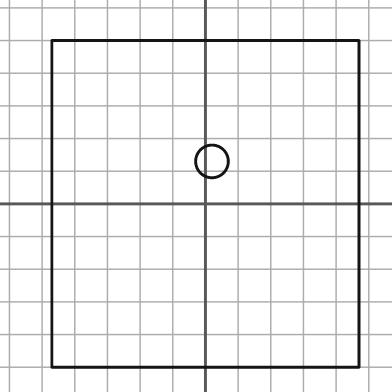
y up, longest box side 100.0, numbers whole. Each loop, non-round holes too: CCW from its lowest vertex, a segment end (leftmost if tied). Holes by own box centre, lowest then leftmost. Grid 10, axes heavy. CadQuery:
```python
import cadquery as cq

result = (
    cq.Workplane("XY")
    .moveTo(-47.0, -50.0)
    .lineTo(47.0, -50.0)
    .lineTo(47.0, 50.0)
    .lineTo(-47.0, 50.0)
    .close()
    .moveTo(2.0, 13.0)
    .circle(5.0)
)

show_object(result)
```